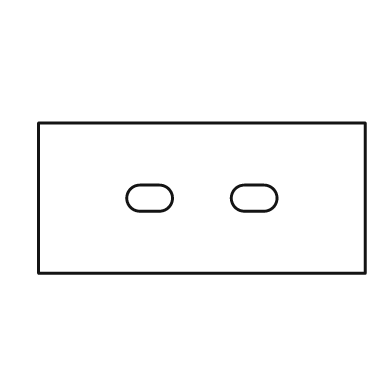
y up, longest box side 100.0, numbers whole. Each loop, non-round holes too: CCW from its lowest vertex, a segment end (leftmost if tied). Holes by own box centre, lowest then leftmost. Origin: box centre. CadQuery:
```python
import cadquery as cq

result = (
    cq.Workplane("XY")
    .moveTo(-50.0, -23.0)
    .lineTo(50.0, -23.0)
    .lineTo(50.0, 23.0)
    .lineTo(-50.0, 23.0)
    .close()
    .moveTo(-19.0, -4.0)
    .lineTo(-13.0, -4.0)
    .threePointArc((-9.0, 0.0), (-13.0, 4.0))
    .lineTo(-19.0, 4.0)
    .threePointArc((-23.0, 0.0), (-19.0, -4.0))
    .close()
    .moveTo(13.0, -4.0)
    .lineTo(19.0, -4.0)
    .threePointArc((23.0, 0.0), (19.0, 4.0))
    .lineTo(13.0, 4.0)
    .threePointArc((9.0, 0.0), (13.0, -4.0))
    .close()
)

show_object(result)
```